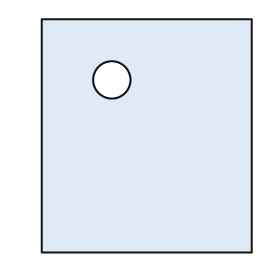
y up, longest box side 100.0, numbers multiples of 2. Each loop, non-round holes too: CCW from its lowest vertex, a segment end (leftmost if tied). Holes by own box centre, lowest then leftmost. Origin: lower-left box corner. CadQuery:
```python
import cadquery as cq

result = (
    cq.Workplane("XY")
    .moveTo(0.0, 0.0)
    .lineTo(90.0, 0.0)
    .lineTo(90.0, 100.0)
    .lineTo(0.0, 100.0)
    .close()
    .moveTo(30.0, 74.0)
    .circle(8.0)
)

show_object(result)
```